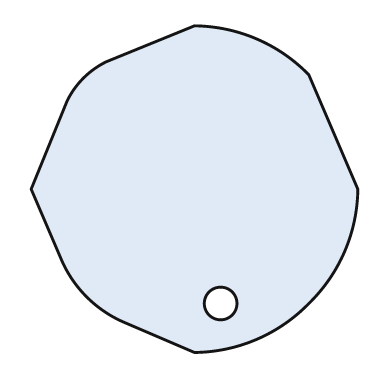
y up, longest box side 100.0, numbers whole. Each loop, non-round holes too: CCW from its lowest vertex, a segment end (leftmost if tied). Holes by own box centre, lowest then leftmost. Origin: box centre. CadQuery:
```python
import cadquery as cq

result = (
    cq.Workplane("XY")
    .moveTo(0.0, -50.0)
    .threePointArc((19.0, -46.0), (35.0, -35.0))
    .threePointArc((46.0, -19.0), (50.0, 0.0))
    .lineTo(35.0, 35.0)
    .threePointArc((19.0, 46.0), (0.0, 50.0))
    .lineTo(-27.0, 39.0)
    .threePointArc((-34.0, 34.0), (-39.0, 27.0))
    .lineTo(-50.0, 0.0)
    .lineTo(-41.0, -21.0)
    .threePointArc((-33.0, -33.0), (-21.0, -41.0))
    .close()
    .moveTo(8.0, -35.0)
    .circle(5.0)
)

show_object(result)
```